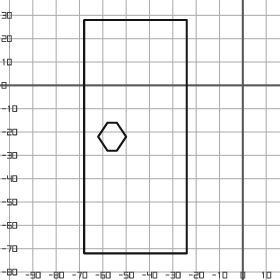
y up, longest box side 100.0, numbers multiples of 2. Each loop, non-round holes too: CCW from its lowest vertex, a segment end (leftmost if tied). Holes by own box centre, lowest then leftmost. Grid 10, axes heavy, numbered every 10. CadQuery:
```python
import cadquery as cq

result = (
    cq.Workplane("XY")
    .moveTo(-68.0, -72.0)
    .lineTo(-24.0, -72.0)
    .lineTo(-24.0, 28.0)
    .lineTo(-68.0, 28.0)
    .close()
    .moveTo(-58.0, -28.0)
    .lineTo(-54.0, -28.0)
    .lineTo(-50.0, -22.0)
    .lineTo(-54.0, -16.0)
    .lineTo(-58.0, -16.0)
    .lineTo(-62.0, -22.0)
    .close()
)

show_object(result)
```